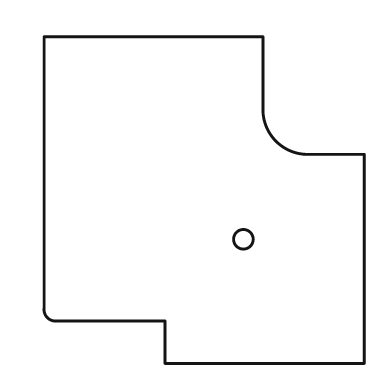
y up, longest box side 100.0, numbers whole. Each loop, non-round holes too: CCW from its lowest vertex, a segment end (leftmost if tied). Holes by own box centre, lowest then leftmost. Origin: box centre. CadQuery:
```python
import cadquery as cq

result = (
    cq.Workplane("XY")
    .moveTo(-12.0, -50.0)
    .lineTo(49.0, -50.0)
    .lineTo(49.0, 14.0)
    .lineTo(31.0, 14.0)
    .threePointArc((22.0, 18.0), (18.0, 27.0))
    .lineTo(18.0, 50.0)
    .lineTo(-49.0, 50.0)
    .lineTo(-49.0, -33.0)
    .threePointArc((-48.0, -36.0), (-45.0, -37.0))
    .lineTo(-12.0, -37.0)
    .close()
    .moveTo(12.0, -12.0)
    .circle(3.0)
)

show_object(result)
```